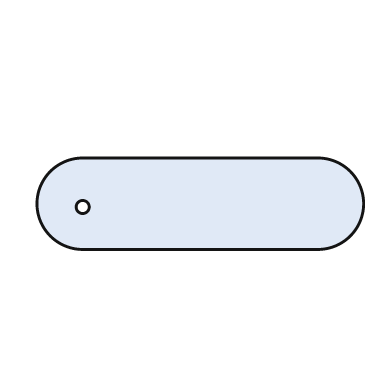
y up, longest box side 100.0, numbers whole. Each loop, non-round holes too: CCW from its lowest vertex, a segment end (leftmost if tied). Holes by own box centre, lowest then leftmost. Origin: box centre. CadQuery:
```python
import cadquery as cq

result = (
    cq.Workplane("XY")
    .moveTo(-36.0, -14.0)
    .lineTo(36.0, -14.0)
    .threePointArc((50.0, 0.0), (36.0, 14.0))
    .lineTo(-36.0, 14.0)
    .threePointArc((-50.0, 0.0), (-36.0, -14.0))
    .close()
    .moveTo(-36.0, -1.0)
    .circle(2.0)
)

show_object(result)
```